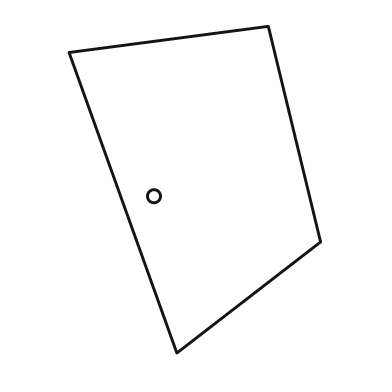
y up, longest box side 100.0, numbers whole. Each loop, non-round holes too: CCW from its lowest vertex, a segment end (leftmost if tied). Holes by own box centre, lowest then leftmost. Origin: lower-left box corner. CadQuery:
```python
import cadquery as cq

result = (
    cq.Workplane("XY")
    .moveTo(33.0, 0.0)
    .lineTo(77.0, 34.0)
    .lineTo(61.0, 100.0)
    .lineTo(0.0, 92.0)
    .close()
    .moveTo(26.0, 48.0)
    .circle(2.0)
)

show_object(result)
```